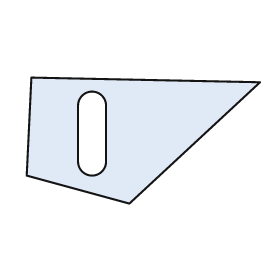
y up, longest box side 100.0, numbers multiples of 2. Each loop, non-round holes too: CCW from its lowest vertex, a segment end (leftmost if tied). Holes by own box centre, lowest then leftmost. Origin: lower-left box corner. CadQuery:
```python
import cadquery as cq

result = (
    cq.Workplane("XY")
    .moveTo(44.0, 0.0)
    .lineTo(100.0, 52.0)
    .lineTo(2.0, 54.0)
    .lineTo(0.0, 12.0)
    .close()
    .moveTo(22.0, 18.0)
    .threePointArc((28.0, 12.0), (34.0, 18.0))
    .lineTo(34.0, 42.0)
    .threePointArc((28.0, 48.0), (22.0, 42.0))
    .close()
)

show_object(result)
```